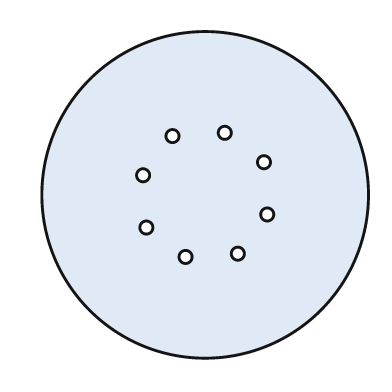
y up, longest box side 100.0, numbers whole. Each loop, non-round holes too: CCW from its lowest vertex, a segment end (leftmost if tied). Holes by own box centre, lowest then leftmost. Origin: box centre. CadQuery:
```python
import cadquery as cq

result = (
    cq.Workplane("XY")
    .moveTo(0.0, 0.0)
    .circle(50.0)
    .moveTo(-6.0, -19.0)
    .circle(2.0)
    .moveTo(10.0, -18.0)
    .circle(2.0)
    .moveTo(-18.0, -10.0)
    .circle(2.0)
    .moveTo(19.0, -6.0)
    .circle(2.0)
    .moveTo(-19.0, 6.0)
    .circle(2.0)
    .moveTo(18.0, 10.0)
    .circle(2.0)
    .moveTo(-10.0, 18.0)
    .circle(2.0)
    .moveTo(6.0, 19.0)
    .circle(2.0)
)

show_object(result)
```